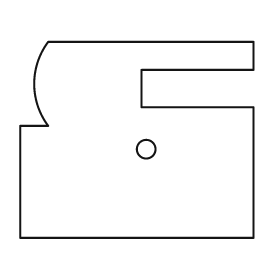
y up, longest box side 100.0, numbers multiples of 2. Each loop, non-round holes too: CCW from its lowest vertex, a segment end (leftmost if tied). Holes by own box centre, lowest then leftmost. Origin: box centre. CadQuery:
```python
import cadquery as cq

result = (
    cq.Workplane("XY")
    .moveTo(-50.0, -42.0)
    .lineTo(50.0, -42.0)
    .lineTo(50.0, 14.0)
    .lineTo(2.0, 14.0)
    .lineTo(2.0, 30.0)
    .lineTo(50.0, 30.0)
    .lineTo(50.0, 42.0)
    .lineTo(-38.0, 42.0)
    .threePointArc((-44.0, 24.0), (-38.0, 6.0))
    .lineTo(-50.0, 6.0)
    .close()
    .moveTo(4.0, -4.0)
    .circle(4.0)
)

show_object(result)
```